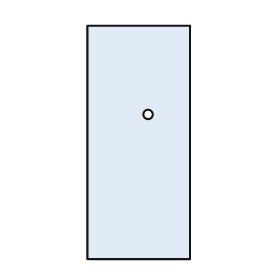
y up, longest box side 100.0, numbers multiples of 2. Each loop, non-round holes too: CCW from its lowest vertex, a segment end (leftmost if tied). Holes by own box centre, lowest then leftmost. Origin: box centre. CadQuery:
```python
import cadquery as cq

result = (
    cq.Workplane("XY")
    .moveTo(-22.0, -50.0)
    .lineTo(22.0, -50.0)
    .lineTo(22.0, 50.0)
    .lineTo(-22.0, 50.0)
    .close()
    .moveTo(4.0, 12.0)
    .circle(2.0)
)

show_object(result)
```